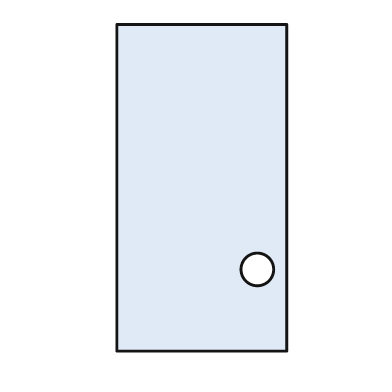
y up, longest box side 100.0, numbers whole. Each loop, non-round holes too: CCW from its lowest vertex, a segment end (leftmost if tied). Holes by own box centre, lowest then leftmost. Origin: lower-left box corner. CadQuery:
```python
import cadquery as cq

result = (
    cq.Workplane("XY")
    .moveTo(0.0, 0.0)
    .lineTo(52.0, 0.0)
    .lineTo(52.0, 100.0)
    .lineTo(0.0, 100.0)
    .close()
    .moveTo(43.0, 25.0)
    .circle(5.0)
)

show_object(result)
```